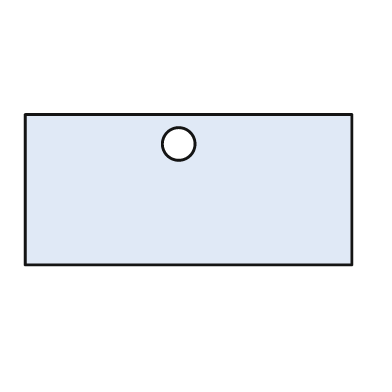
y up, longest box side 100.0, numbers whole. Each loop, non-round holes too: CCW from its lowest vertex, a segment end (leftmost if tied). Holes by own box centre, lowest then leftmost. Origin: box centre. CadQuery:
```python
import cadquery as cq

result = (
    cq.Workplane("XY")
    .moveTo(-50.0, -23.0)
    .lineTo(50.0, -23.0)
    .lineTo(50.0, 23.0)
    .lineTo(-50.0, 23.0)
    .close()
    .moveTo(-3.0, 14.0)
    .circle(5.0)
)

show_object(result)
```